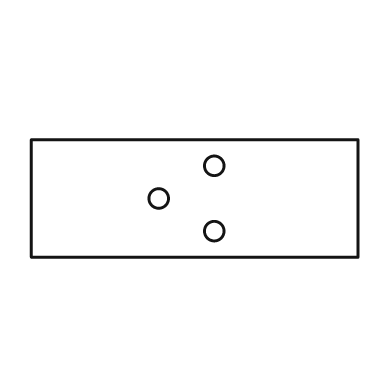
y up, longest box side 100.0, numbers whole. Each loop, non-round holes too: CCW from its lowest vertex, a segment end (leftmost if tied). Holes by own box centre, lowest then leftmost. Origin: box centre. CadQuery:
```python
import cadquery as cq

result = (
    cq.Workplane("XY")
    .moveTo(-50.0, -18.0)
    .lineTo(50.0, -18.0)
    .lineTo(50.0, 18.0)
    .lineTo(-50.0, 18.0)
    .close()
    .moveTo(6.0, -10.0)
    .circle(3.0)
    .moveTo(-11.0, 0.0)
    .circle(3.0)
    .moveTo(6.0, 10.0)
    .circle(3.0)
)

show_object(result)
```